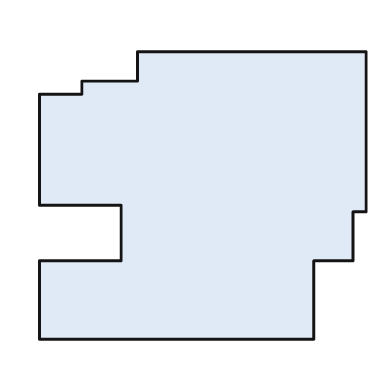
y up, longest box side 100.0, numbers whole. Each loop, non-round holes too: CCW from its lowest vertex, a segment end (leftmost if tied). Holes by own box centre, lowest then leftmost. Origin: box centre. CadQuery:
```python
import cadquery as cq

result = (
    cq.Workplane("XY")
    .moveTo(-50.0, -44.0)
    .lineTo(34.0, -44.0)
    .lineTo(34.0, -20.0)
    .lineTo(46.0, -20.0)
    .lineTo(46.0, -5.0)
    .lineTo(50.0, -5.0)
    .lineTo(50.0, 44.0)
    .lineTo(-20.0, 44.0)
    .lineTo(-20.0, 35.0)
    .lineTo(-37.0, 35.0)
    .lineTo(-37.0, 31.0)
    .lineTo(-50.0, 31.0)
    .lineTo(-50.0, -3.0)
    .lineTo(-25.0, -3.0)
    .lineTo(-25.0, -20.0)
    .lineTo(-50.0, -20.0)
    .close()
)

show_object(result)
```